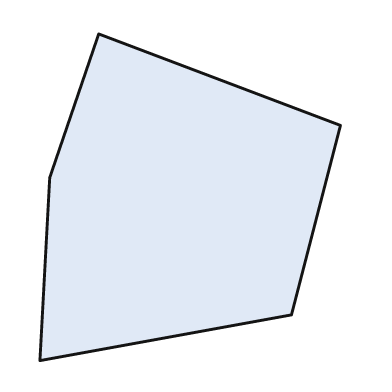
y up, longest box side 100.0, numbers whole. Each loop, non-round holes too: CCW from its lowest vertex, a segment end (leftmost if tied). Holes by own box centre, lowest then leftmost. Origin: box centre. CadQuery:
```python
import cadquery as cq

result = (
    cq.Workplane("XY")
    .moveTo(-46.0, -50.0)
    .lineTo(31.0, -36.0)
    .lineTo(46.0, 22.0)
    .lineTo(-28.0, 50.0)
    .lineTo(-43.0, 6.0)
    .close()
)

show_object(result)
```